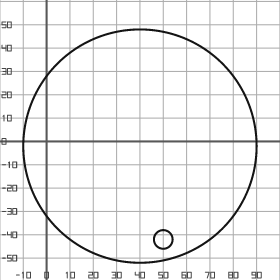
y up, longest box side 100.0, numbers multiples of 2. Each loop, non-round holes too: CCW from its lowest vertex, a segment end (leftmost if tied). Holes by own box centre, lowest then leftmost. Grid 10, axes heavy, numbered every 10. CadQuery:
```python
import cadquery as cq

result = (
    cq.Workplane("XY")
    .moveTo(40.0, -2.0)
    .circle(50.0)
    .moveTo(50.0, -42.0)
    .circle(4.0)
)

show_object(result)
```